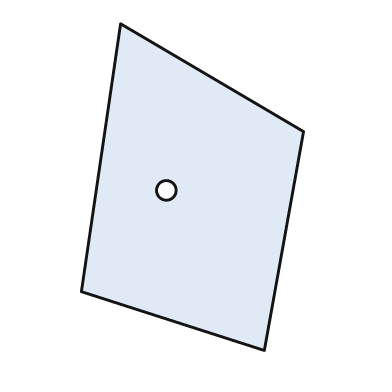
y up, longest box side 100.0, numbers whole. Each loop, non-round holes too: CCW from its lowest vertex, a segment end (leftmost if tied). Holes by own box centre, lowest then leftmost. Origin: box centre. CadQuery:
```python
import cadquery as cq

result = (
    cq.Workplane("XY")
    .moveTo(22.0, -50.0)
    .lineTo(34.0, 17.0)
    .lineTo(-22.0, 50.0)
    .lineTo(-34.0, -32.0)
    .close()
    .moveTo(-8.0, -1.0)
    .circle(3.0)
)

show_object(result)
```